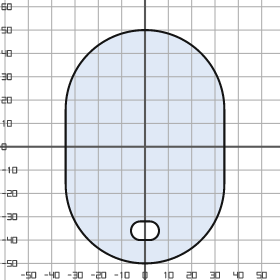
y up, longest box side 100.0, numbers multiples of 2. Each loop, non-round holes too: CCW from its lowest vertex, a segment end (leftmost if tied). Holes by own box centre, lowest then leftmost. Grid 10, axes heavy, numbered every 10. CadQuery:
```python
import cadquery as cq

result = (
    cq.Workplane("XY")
    .moveTo(-34.0, -16.0)
    .threePointArc((0.0, -50.0), (34.0, -16.0))
    .lineTo(34.0, 16.0)
    .threePointArc((0.0, 50.0), (-34.0, 16.0))
    .close()
    .moveTo(-2.0, -40.0)
    .lineTo(2.0, -40.0)
    .threePointArc((6.0, -36.0), (2.0, -32.0))
    .lineTo(-2.0, -32.0)
    .threePointArc((-6.0, -36.0), (-2.0, -40.0))
    .close()
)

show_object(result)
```